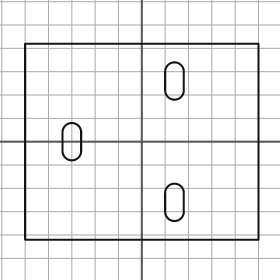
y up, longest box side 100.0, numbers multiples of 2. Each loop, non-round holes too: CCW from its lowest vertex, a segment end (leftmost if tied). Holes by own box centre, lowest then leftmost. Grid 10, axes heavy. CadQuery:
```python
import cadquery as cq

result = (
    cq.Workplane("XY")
    .moveTo(-50.0, -42.0)
    .lineTo(50.0, -42.0)
    .lineTo(50.0, 42.0)
    .lineTo(-50.0, 42.0)
    .close()
    .moveTo(10.0, -30.0)
    .threePointArc((14.0, -34.0), (18.0, -30.0))
    .lineTo(18.0, -22.0)
    .threePointArc((14.0, -18.0), (10.0, -22.0))
    .close()
    .moveTo(-34.0, -4.0)
    .threePointArc((-30.0, -8.0), (-26.0, -4.0))
    .lineTo(-26.0, 4.0)
    .threePointArc((-30.0, 8.0), (-34.0, 4.0))
    .close()
    .moveTo(10.0, 22.0)
    .threePointArc((14.0, 18.0), (18.0, 22.0))
    .lineTo(18.0, 30.0)
    .threePointArc((14.0, 34.0), (10.0, 30.0))
    .close()
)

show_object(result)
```